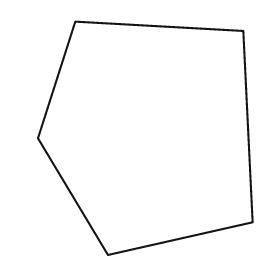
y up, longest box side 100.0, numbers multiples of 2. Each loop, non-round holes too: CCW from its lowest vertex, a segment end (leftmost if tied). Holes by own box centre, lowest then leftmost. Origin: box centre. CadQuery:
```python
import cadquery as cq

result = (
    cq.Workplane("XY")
    .moveTo(-16.0, -50.0)
    .lineTo(46.0, -36.0)
    .lineTo(42.0, 46.0)
    .lineTo(-30.0, 50.0)
    .lineTo(-46.0, 0.0)
    .close()
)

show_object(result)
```